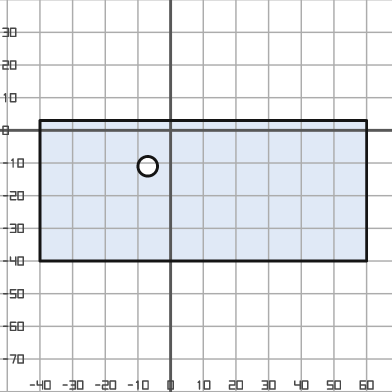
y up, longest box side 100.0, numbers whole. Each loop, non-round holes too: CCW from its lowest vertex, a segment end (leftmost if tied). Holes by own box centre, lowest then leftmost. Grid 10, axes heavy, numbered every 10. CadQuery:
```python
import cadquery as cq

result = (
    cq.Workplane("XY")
    .moveTo(-40.0, -40.0)
    .lineTo(60.0, -40.0)
    .lineTo(60.0, 3.0)
    .lineTo(-40.0, 3.0)
    .close()
    .moveTo(-7.0, -11.0)
    .circle(3.0)
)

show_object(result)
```